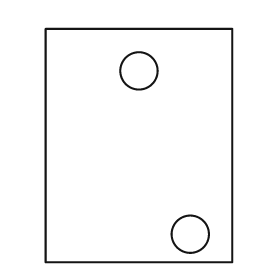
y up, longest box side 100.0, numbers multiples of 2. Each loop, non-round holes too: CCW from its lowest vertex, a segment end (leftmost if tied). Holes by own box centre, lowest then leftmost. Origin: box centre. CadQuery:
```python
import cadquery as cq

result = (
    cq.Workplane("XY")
    .moveTo(-40.0, -50.0)
    .lineTo(40.0, -50.0)
    .lineTo(40.0, 50.0)
    .lineTo(-40.0, 50.0)
    .close()
    .moveTo(22.0, -38.0)
    .circle(8.0)
    .moveTo(0.0, 32.0)
    .circle(8.0)
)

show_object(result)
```